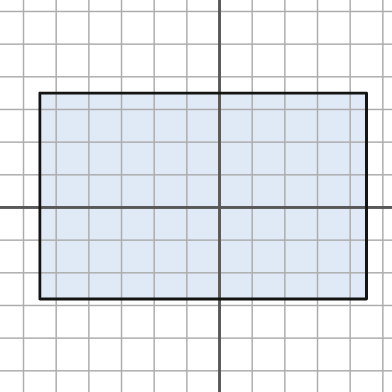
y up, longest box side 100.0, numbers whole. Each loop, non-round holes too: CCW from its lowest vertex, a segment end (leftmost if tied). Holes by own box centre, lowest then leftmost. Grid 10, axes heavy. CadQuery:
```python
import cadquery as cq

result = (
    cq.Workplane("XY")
    .moveTo(-55.0, -28.0)
    .lineTo(45.0, -28.0)
    .lineTo(45.0, 35.0)
    .lineTo(-55.0, 35.0)
    .close()
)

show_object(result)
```